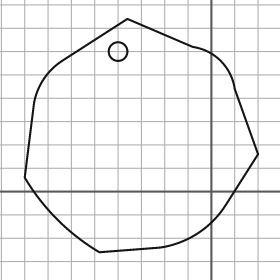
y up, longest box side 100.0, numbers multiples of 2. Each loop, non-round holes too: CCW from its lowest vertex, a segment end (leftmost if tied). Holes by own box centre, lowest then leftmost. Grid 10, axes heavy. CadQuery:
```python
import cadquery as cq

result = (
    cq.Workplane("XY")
    .moveTo(-48.0, -26.0)
    .lineTo(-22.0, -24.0)
    .threePointArc((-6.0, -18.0), (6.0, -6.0))
    .lineTo(20.0, 16.0)
    .lineTo(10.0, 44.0)
    .threePointArc((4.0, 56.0), (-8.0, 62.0))
    .lineTo(-36.0, 74.0)
    .lineTo(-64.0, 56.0)
    .threePointArc((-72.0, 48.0), (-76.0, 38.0))
    .lineTo(-80.0, 6.0)
    .threePointArc((-66.0, -12.0), (-48.0, -26.0))
    .close()
    .moveTo(-40.0, 60.0)
    .circle(4.0)
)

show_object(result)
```